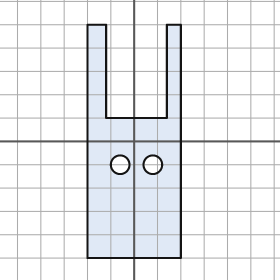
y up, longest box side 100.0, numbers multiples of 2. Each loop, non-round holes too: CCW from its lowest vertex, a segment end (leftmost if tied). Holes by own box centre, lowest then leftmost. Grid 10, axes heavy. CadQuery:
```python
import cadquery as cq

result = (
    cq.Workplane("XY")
    .moveTo(-20.0, -50.0)
    .lineTo(20.0, -50.0)
    .lineTo(20.0, 50.0)
    .lineTo(14.0, 50.0)
    .lineTo(14.0, 10.0)
    .lineTo(-12.0, 10.0)
    .lineTo(-12.0, 50.0)
    .lineTo(-20.0, 50.0)
    .close()
    .moveTo(-6.0, -10.0)
    .circle(4.0)
    .moveTo(8.0, -10.0)
    .circle(4.0)
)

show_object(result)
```